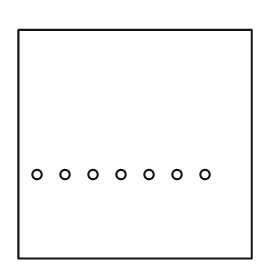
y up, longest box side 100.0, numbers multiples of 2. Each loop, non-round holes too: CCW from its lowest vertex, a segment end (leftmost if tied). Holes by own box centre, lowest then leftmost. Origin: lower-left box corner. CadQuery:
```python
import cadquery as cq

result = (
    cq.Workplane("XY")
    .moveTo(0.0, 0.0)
    .lineTo(100.0, 0.0)
    .lineTo(100.0, 98.0)
    .lineTo(0.0, 98.0)
    .close()
    .moveTo(8.0, 36.0)
    .circle(2.0)
    .moveTo(20.0, 36.0)
    .circle(2.0)
    .moveTo(32.0, 36.0)
    .circle(2.0)
    .moveTo(44.0, 36.0)
    .circle(2.0)
    .moveTo(56.0, 36.0)
    .circle(2.0)
    .moveTo(68.0, 36.0)
    .circle(2.0)
    .moveTo(80.0, 36.0)
    .circle(2.0)
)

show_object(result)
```